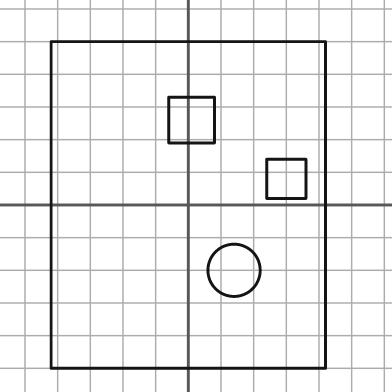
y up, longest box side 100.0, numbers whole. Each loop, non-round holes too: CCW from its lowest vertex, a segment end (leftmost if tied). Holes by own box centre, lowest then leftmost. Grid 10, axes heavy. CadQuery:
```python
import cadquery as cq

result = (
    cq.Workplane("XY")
    .moveTo(-42.0, -50.0)
    .lineTo(42.0, -50.0)
    .lineTo(42.0, 50.0)
    .lineTo(-42.0, 50.0)
    .close()
    .moveTo(14.0, -20.0)
    .circle(8.0)
    .moveTo(24.0, 2.0)
    .lineTo(36.0, 2.0)
    .lineTo(36.0, 14.0)
    .lineTo(24.0, 14.0)
    .close()
    .moveTo(-6.0, 19.0)
    .lineTo(8.0, 19.0)
    .lineTo(8.0, 33.0)
    .lineTo(-6.0, 33.0)
    .close()
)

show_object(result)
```